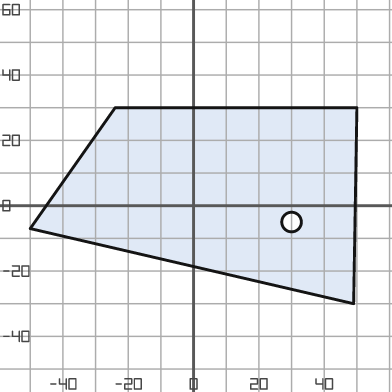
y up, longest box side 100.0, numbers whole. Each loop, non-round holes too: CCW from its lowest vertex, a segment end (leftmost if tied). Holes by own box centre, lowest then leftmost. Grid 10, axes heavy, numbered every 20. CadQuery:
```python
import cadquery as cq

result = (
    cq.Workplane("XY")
    .moveTo(49.0, -30.0)
    .lineTo(50.0, 30.0)
    .lineTo(-24.0, 30.0)
    .lineTo(-50.0, -7.0)
    .close()
    .moveTo(30.0, -5.0)
    .circle(3.0)
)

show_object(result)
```